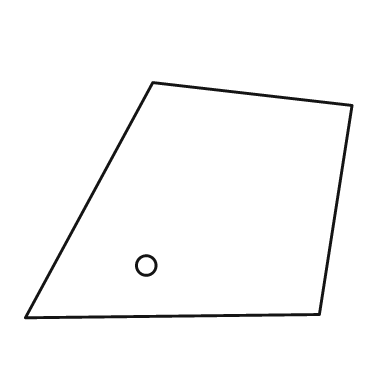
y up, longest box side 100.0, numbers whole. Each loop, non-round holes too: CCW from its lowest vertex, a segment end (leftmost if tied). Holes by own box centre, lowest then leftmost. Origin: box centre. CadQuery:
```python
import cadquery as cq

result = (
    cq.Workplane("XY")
    .moveTo(-50.0, -36.0)
    .lineTo(40.0, -35.0)
    .lineTo(50.0, 29.0)
    .lineTo(-11.0, 36.0)
    .close()
    .moveTo(-13.0, -20.0)
    .circle(3.0)
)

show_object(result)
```